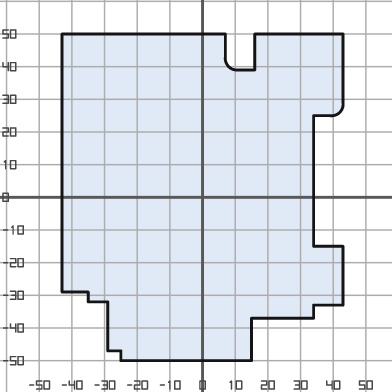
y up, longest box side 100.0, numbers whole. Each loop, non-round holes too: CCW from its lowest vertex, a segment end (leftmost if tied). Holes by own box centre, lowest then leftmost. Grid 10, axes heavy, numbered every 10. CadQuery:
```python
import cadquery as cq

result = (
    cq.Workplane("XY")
    .moveTo(-25.0, -50.0)
    .lineTo(15.0, -50.0)
    .lineTo(15.0, -37.0)
    .lineTo(34.0, -37.0)
    .lineTo(34.0, -33.0)
    .lineTo(43.0, -33.0)
    .lineTo(43.0, -15.0)
    .lineTo(34.0, -15.0)
    .lineTo(34.0, 25.0)
    .lineTo(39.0, 25.0)
    .threePointArc((42.0, 26.0), (43.0, 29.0))
    .lineTo(43.0, 50.0)
    .lineTo(16.0, 50.0)
    .lineTo(16.0, 39.0)
    .lineTo(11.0, 39.0)
    .threePointArc((8.0, 40.0), (7.0, 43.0))
    .lineTo(7.0, 50.0)
    .lineTo(-43.0, 50.0)
    .lineTo(-43.0, -29.0)
    .lineTo(-35.0, -29.0)
    .lineTo(-35.0, -32.0)
    .lineTo(-29.0, -32.0)
    .lineTo(-29.0, -47.0)
    .lineTo(-25.0, -47.0)
    .close()
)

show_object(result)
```